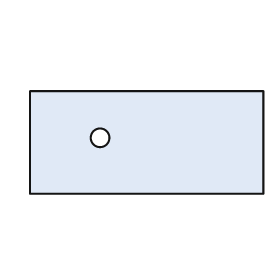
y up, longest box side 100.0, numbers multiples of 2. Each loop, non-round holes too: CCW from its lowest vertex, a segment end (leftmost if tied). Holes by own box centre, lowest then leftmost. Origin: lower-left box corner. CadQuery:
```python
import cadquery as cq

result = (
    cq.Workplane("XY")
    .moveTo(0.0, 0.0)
    .lineTo(100.0, 0.0)
    .lineTo(100.0, 44.0)
    .lineTo(0.0, 44.0)
    .close()
    .moveTo(30.0, 24.0)
    .circle(4.0)
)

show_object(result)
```